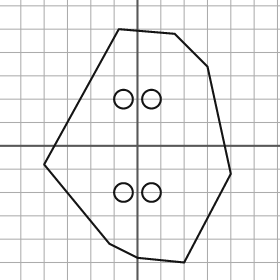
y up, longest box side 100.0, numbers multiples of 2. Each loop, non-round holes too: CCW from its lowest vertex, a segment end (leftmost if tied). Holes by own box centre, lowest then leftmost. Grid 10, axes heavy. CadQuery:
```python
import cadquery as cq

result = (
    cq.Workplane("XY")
    .moveTo(20.0, -50.0)
    .lineTo(40.0, -12.0)
    .lineTo(30.0, 34.0)
    .lineTo(16.0, 48.0)
    .lineTo(-8.0, 50.0)
    .lineTo(-40.0, -8.0)
    .lineTo(-12.0, -42.0)
    .lineTo(0.0, -48.0)
    .close()
    .moveTo(-6.0, -20.0)
    .circle(4.0)
    .moveTo(6.0, -20.0)
    .circle(4.0)
    .moveTo(-6.0, 20.0)
    .circle(4.0)
    .moveTo(6.0, 20.0)
    .circle(4.0)
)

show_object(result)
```